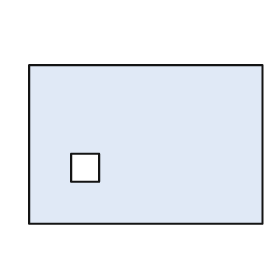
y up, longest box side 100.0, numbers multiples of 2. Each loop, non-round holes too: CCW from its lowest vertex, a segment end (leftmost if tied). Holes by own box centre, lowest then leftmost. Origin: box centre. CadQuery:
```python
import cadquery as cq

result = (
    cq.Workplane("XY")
    .moveTo(-50.0, -34.0)
    .lineTo(50.0, -34.0)
    .lineTo(50.0, 34.0)
    .lineTo(-50.0, 34.0)
    .close()
    .moveTo(-32.0, -16.0)
    .lineTo(-20.0, -16.0)
    .lineTo(-20.0, -4.0)
    .lineTo(-32.0, -4.0)
    .close()
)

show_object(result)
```